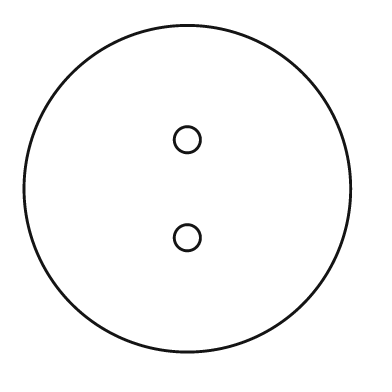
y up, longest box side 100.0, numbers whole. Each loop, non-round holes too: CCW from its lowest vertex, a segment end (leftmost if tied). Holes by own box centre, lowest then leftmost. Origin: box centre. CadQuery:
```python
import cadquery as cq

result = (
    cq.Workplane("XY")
    .moveTo(0.0, 0.0)
    .circle(50.0)
    .moveTo(0.0, -15.0)
    .circle(4.0)
    .moveTo(0.0, 15.0)
    .circle(4.0)
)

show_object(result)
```